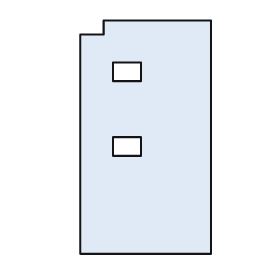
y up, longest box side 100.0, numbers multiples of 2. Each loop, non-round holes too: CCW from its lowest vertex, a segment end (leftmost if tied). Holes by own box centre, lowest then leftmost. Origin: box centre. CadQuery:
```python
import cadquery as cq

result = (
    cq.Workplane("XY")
    .moveTo(-28.0, -50.0)
    .lineTo(28.0, -50.0)
    .lineTo(28.0, 50.0)
    .lineTo(-18.0, 50.0)
    .lineTo(-18.0, 44.0)
    .lineTo(-28.0, 44.0)
    .close()
    .moveTo(-14.0, -8.0)
    .lineTo(-2.0, -8.0)
    .lineTo(-2.0, 0.0)
    .lineTo(-14.0, 0.0)
    .close()
    .moveTo(-14.0, 24.0)
    .lineTo(-2.0, 24.0)
    .lineTo(-2.0, 32.0)
    .lineTo(-14.0, 32.0)
    .close()
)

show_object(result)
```